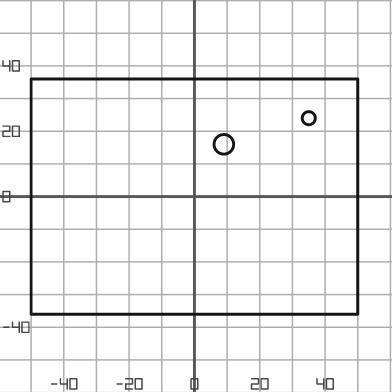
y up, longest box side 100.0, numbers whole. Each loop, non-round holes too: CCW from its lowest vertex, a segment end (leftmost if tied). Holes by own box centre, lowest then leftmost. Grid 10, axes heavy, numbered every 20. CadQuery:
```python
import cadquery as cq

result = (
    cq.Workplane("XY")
    .moveTo(-50.0, -36.0)
    .lineTo(50.0, -36.0)
    .lineTo(50.0, 36.0)
    .lineTo(-50.0, 36.0)
    .close()
    .moveTo(9.0, 16.0)
    .circle(3.0)
    .moveTo(35.0, 24.0)
    .circle(2.0)
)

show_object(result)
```